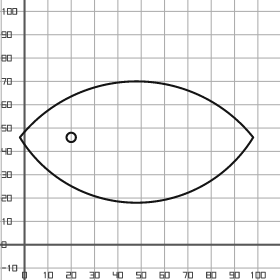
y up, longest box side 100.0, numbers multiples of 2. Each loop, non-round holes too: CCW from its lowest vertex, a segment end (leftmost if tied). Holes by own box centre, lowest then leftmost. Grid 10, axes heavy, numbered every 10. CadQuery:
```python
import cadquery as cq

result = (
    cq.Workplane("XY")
    .moveTo(-2.0, 46.0)
    .threePointArc((48.0, 18.0), (98.0, 46.0))
    .threePointArc((48.0, 70.0), (-2.0, 46.0))
    .close()
    .moveTo(20.0, 46.0)
    .circle(2.0)
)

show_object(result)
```